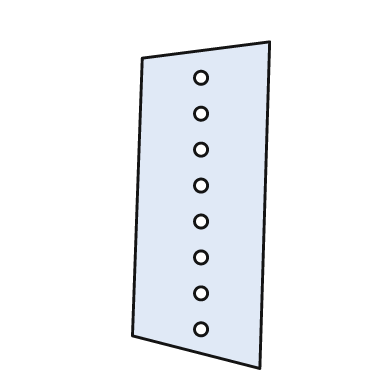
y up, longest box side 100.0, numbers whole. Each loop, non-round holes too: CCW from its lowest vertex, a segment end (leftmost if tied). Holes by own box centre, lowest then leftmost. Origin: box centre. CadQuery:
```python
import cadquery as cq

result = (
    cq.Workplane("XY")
    .moveTo(18.0, -50.0)
    .lineTo(21.0, 50.0)
    .lineTo(-18.0, 45.0)
    .lineTo(-21.0, -40.0)
    .close()
    .moveTo(0.0, -38.0)
    .circle(2.0)
    .moveTo(0.0, -27.0)
    .circle(2.0)
    .moveTo(0.0, -16.0)
    .circle(2.0)
    .moveTo(0.0, -5.0)
    .circle(2.0)
    .moveTo(0.0, 6.0)
    .circle(2.0)
    .moveTo(0.0, 17.0)
    .circle(2.0)
    .moveTo(0.0, 28.0)
    .circle(2.0)
    .moveTo(0.0, 39.0)
    .circle(2.0)
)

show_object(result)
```